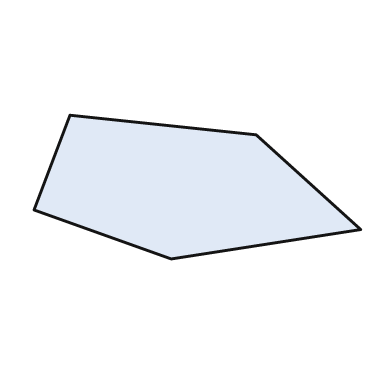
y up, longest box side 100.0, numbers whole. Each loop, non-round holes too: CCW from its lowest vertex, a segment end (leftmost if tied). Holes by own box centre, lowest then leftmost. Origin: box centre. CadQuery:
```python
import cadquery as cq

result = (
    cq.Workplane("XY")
    .moveTo(-8.0, -22.0)
    .lineTo(50.0, -13.0)
    .lineTo(18.0, 16.0)
    .lineTo(-39.0, 22.0)
    .lineTo(-50.0, -7.0)
    .close()
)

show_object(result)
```